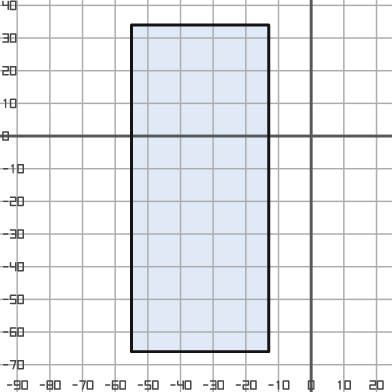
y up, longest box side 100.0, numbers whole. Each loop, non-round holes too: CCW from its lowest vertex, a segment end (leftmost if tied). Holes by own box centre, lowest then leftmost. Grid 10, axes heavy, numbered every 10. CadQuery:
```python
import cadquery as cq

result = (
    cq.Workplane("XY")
    .moveTo(-55.0, -66.0)
    .lineTo(-13.0, -66.0)
    .lineTo(-13.0, 34.0)
    .lineTo(-55.0, 34.0)
    .close()
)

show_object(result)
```